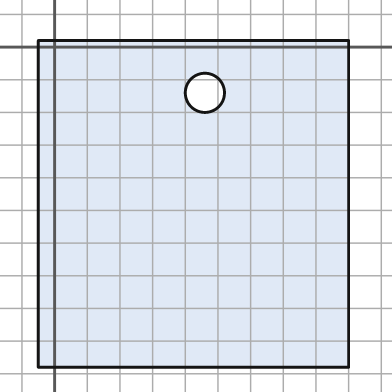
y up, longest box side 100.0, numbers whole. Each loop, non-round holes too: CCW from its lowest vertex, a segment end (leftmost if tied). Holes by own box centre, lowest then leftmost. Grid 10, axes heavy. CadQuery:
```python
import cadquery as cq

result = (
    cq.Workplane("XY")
    .moveTo(-5.0, -98.0)
    .lineTo(90.0, -98.0)
    .lineTo(90.0, 2.0)
    .lineTo(-5.0, 2.0)
    .close()
    .moveTo(46.0, -14.0)
    .circle(6.0)
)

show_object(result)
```